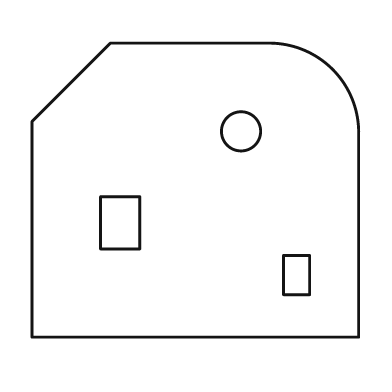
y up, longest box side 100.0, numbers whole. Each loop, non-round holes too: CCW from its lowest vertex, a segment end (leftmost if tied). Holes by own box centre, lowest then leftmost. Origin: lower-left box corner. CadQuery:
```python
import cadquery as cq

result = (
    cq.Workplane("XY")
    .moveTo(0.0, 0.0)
    .lineTo(100.0, 0.0)
    .lineTo(100.0, 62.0)
    .threePointArc((92.0, 82.0), (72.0, 90.0))
    .lineTo(24.0, 90.0)
    .lineTo(0.0, 66.0)
    .close()
    .moveTo(77.0, 13.0)
    .lineTo(85.0, 13.0)
    .lineTo(85.0, 25.0)
    .lineTo(77.0, 25.0)
    .close()
    .moveTo(21.0, 27.0)
    .lineTo(33.0, 27.0)
    .lineTo(33.0, 43.0)
    .lineTo(21.0, 43.0)
    .close()
    .moveTo(64.0, 63.0)
    .circle(6.0)
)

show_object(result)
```